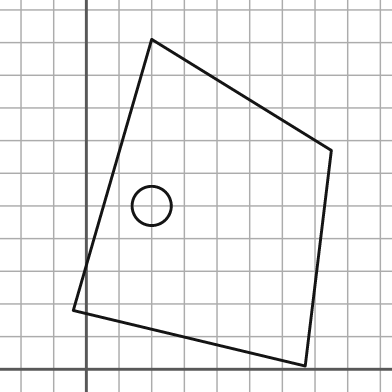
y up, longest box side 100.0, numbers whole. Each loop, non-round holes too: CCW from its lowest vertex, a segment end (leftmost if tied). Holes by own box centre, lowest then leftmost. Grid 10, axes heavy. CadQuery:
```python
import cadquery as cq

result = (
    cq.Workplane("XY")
    .moveTo(67.0, 1.0)
    .lineTo(75.0, 67.0)
    .lineTo(20.0, 101.0)
    .lineTo(-4.0, 18.0)
    .close()
    .moveTo(20.0, 50.0)
    .circle(6.0)
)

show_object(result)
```